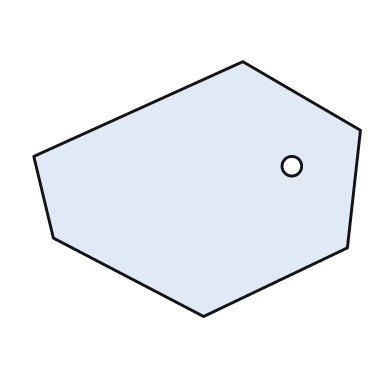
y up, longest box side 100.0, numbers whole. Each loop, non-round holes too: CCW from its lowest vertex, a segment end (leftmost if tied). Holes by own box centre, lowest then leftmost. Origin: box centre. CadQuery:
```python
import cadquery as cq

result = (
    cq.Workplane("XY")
    .moveTo(2.0, -39.0)
    .lineTo(46.0, -18.0)
    .lineTo(50.0, 18.0)
    .lineTo(14.0, 39.0)
    .lineTo(-50.0, 10.0)
    .lineTo(-44.0, -15.0)
    .close()
    .moveTo(29.0, 7.0)
    .circle(3.0)
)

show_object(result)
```